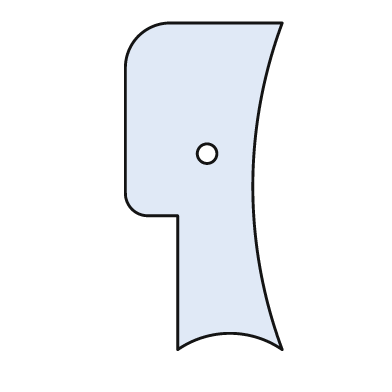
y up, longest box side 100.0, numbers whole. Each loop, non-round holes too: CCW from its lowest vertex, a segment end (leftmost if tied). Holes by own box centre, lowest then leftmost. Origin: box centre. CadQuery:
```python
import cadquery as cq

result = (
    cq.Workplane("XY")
    .moveTo(-8.0, -50.0)
    .threePointArc((8.0, -45.0), (24.0, -50.0))
    .threePointArc((15.0, 0.0), (24.0, 50.0))
    .lineTo(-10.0, 50.0)
    .threePointArc((-20.0, 46.0), (-24.0, 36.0))
    .lineTo(-24.0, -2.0)
    .threePointArc((-22.0, -7.0), (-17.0, -9.0))
    .lineTo(-8.0, -9.0)
    .close()
    .moveTo(1.0, 10.0)
    .circle(3.0)
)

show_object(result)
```